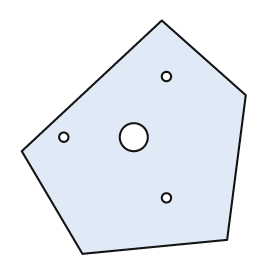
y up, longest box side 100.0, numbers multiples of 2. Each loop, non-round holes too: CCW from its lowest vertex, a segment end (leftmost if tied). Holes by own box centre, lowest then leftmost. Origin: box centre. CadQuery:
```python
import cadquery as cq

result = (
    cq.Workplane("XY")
    .moveTo(-22.0, -50.0)
    .lineTo(40.0, -44.0)
    .lineTo(48.0, 18.0)
    .lineTo(12.0, 50.0)
    .lineTo(-48.0, -6.0)
    .close()
    .moveTo(14.0, -26.0)
    .circle(2.0)
    .moveTo(-30.0, 0.0)
    .circle(2.0)
    .moveTo(0.0, 0.0)
    .circle(6.0)
    .moveTo(14.0, 26.0)
    .circle(2.0)
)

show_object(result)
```